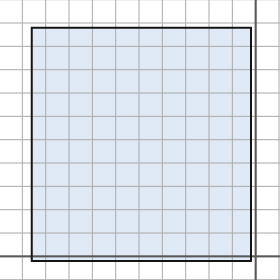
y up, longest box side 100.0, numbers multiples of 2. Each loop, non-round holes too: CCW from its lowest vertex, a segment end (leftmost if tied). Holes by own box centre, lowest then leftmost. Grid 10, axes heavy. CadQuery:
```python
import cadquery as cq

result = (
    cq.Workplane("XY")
    .moveTo(-96.0, -2.0)
    .lineTo(-2.0, -2.0)
    .lineTo(-2.0, 98.0)
    .lineTo(-96.0, 98.0)
    .close()
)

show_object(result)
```